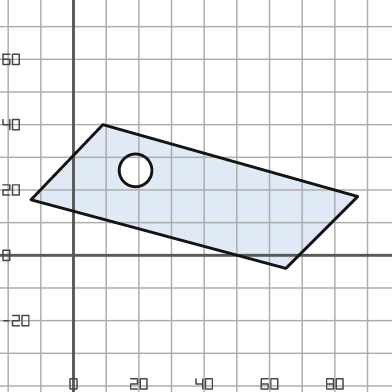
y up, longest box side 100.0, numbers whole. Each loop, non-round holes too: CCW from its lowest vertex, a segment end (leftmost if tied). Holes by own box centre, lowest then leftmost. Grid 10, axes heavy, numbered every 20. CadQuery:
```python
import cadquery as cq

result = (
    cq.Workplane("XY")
    .moveTo(65.0, -4.0)
    .lineTo(87.0, 18.0)
    .lineTo(9.0, 40.0)
    .lineTo(-13.0, 17.0)
    .close()
    .moveTo(19.0, 26.0)
    .circle(5.0)
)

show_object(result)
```